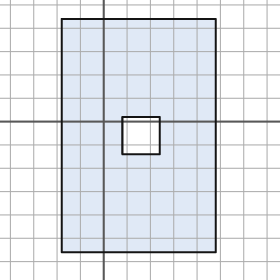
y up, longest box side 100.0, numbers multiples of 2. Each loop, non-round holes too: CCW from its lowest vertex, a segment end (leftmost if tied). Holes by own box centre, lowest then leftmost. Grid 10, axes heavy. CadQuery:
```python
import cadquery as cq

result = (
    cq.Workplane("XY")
    .moveTo(-18.0, -56.0)
    .lineTo(48.0, -56.0)
    .lineTo(48.0, 44.0)
    .lineTo(-18.0, 44.0)
    .close()
    .moveTo(8.0, -14.0)
    .lineTo(24.0, -14.0)
    .lineTo(24.0, 2.0)
    .lineTo(8.0, 2.0)
    .close()
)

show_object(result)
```